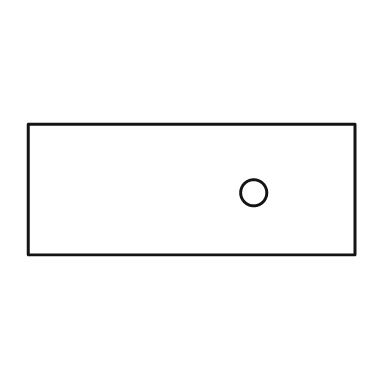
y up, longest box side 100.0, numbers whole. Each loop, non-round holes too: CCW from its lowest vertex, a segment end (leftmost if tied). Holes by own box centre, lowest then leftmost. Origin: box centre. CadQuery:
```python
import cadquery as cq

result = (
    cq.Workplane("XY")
    .moveTo(-50.0, -20.0)
    .lineTo(50.0, -20.0)
    .lineTo(50.0, 20.0)
    .lineTo(-50.0, 20.0)
    .close()
    .moveTo(19.0, -1.0)
    .circle(4.0)
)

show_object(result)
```